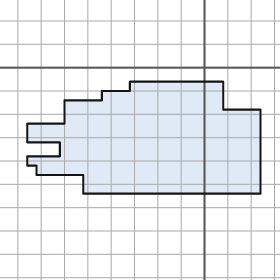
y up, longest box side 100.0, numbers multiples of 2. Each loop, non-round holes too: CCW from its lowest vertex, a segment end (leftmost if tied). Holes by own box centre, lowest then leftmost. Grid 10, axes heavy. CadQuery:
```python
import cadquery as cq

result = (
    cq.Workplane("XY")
    .moveTo(-52.0, -54.0)
    .lineTo(24.0, -54.0)
    .lineTo(24.0, -18.0)
    .lineTo(8.0, -18.0)
    .lineTo(8.0, -6.0)
    .lineTo(-32.0, -6.0)
    .lineTo(-32.0, -10.0)
    .lineTo(-44.0, -10.0)
    .lineTo(-44.0, -14.0)
    .lineTo(-60.0, -14.0)
    .lineTo(-60.0, -24.0)
    .lineTo(-76.0, -24.0)
    .lineTo(-76.0, -32.0)
    .lineTo(-62.0, -32.0)
    .lineTo(-62.0, -38.0)
    .lineTo(-76.0, -38.0)
    .lineTo(-76.0, -42.0)
    .lineTo(-72.0, -42.0)
    .lineTo(-72.0, -46.0)
    .lineTo(-52.0, -46.0)
    .close()
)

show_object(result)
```